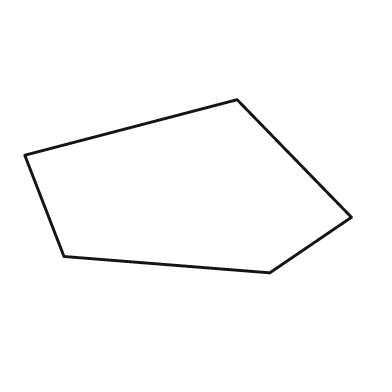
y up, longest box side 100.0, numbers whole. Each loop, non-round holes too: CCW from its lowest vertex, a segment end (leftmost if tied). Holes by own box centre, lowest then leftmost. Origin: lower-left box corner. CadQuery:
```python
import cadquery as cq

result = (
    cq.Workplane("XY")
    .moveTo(75.0, 0.0)
    .lineTo(100.0, 17.0)
    .lineTo(65.0, 53.0)
    .lineTo(0.0, 36.0)
    .lineTo(12.0, 5.0)
    .close()
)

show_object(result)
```